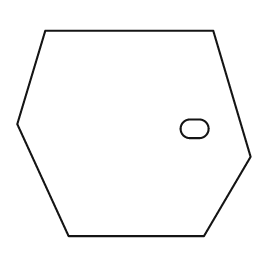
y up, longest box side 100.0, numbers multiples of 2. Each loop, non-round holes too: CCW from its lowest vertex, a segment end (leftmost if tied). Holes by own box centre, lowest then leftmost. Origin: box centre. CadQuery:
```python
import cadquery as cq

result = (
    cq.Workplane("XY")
    .moveTo(-28.0, -44.0)
    .lineTo(30.0, -44.0)
    .lineTo(50.0, -10.0)
    .lineTo(34.0, 44.0)
    .lineTo(-38.0, 44.0)
    .lineTo(-50.0, 4.0)
    .close()
    .moveTo(24.0, -2.0)
    .lineTo(28.0, -2.0)
    .threePointArc((32.0, 2.0), (28.0, 6.0))
    .lineTo(24.0, 6.0)
    .threePointArc((20.0, 2.0), (24.0, -2.0))
    .close()
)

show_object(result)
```